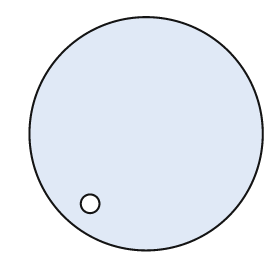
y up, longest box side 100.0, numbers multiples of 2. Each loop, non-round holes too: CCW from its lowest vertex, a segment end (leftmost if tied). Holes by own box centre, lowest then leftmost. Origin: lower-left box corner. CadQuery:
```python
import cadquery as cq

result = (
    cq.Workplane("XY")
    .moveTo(50.0, 50.0)
    .circle(50.0)
    .moveTo(26.0, 20.0)
    .circle(4.0)
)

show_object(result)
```